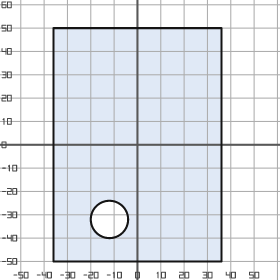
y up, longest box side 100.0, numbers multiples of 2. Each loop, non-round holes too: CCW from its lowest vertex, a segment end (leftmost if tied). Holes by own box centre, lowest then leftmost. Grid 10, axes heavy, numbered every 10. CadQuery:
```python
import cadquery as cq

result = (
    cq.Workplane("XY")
    .moveTo(-36.0, -50.0)
    .lineTo(36.0, -50.0)
    .lineTo(36.0, 50.0)
    .lineTo(-36.0, 50.0)
    .close()
    .moveTo(-12.0, -32.0)
    .circle(8.0)
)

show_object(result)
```